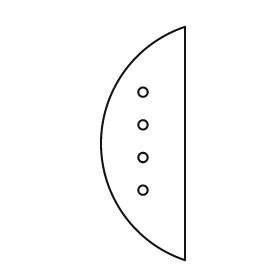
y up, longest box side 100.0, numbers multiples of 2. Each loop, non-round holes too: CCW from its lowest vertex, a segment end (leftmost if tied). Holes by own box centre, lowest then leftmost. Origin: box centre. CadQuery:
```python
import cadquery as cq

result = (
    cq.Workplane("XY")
    .moveTo(18.0, -50.0)
    .lineTo(18.0, 50.0)
    .threePointArc((-18.0, 0.0), (18.0, -50.0))
    .close()
    .moveTo(0.0, -20.0)
    .circle(2.0)
    .moveTo(0.0, -6.0)
    .circle(2.0)
    .moveTo(0.0, 8.0)
    .circle(2.0)
    .moveTo(0.0, 22.0)
    .circle(2.0)
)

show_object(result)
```